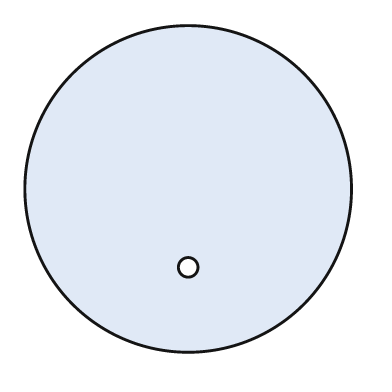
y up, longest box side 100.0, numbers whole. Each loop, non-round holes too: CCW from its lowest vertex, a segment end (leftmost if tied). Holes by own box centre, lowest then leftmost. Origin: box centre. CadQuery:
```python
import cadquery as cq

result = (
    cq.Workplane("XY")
    .moveTo(0.0, 0.0)
    .circle(50.0)
    .moveTo(0.0, -24.0)
    .circle(3.0)
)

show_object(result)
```